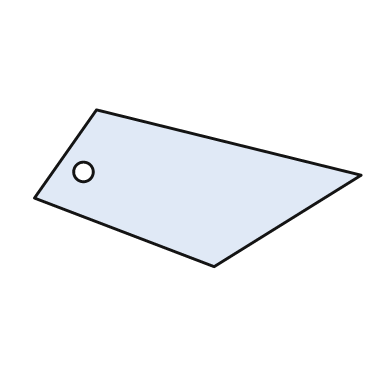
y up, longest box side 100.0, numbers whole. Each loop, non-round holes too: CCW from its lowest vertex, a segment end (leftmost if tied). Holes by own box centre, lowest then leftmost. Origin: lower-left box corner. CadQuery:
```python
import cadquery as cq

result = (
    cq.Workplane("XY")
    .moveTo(55.0, 0.0)
    .lineTo(100.0, 28.0)
    .lineTo(19.0, 48.0)
    .lineTo(0.0, 21.0)
    .close()
    .moveTo(15.0, 29.0)
    .circle(3.0)
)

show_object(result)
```